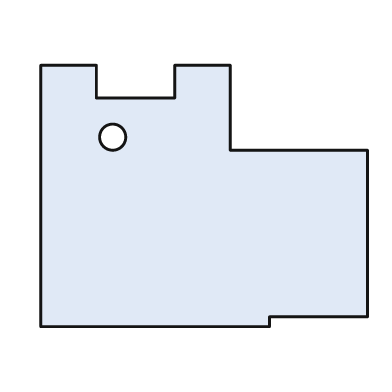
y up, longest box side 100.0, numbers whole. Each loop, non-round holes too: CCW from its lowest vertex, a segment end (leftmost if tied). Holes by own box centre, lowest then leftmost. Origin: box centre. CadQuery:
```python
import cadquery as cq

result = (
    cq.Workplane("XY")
    .moveTo(-50.0, -40.0)
    .lineTo(20.0, -40.0)
    .lineTo(20.0, -37.0)
    .lineTo(50.0, -37.0)
    .lineTo(50.0, 14.0)
    .lineTo(8.0, 14.0)
    .lineTo(8.0, 40.0)
    .lineTo(-9.0, 40.0)
    .lineTo(-9.0, 30.0)
    .lineTo(-33.0, 30.0)
    .lineTo(-33.0, 40.0)
    .lineTo(-50.0, 40.0)
    .close()
    .moveTo(-28.0, 18.0)
    .circle(4.0)
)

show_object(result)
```